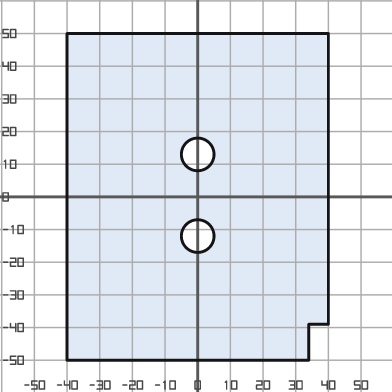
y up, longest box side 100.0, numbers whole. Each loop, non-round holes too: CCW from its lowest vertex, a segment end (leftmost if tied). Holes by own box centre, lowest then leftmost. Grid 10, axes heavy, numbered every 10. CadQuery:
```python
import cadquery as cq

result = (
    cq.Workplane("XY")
    .moveTo(-40.0, -50.0)
    .lineTo(34.0, -50.0)
    .lineTo(34.0, -39.0)
    .lineTo(40.0, -39.0)
    .lineTo(40.0, 50.0)
    .lineTo(-40.0, 50.0)
    .close()
    .moveTo(0.0, -12.0)
    .circle(5.0)
    .moveTo(0.0, 13.0)
    .circle(5.0)
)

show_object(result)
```